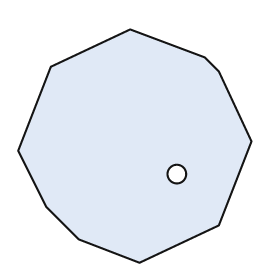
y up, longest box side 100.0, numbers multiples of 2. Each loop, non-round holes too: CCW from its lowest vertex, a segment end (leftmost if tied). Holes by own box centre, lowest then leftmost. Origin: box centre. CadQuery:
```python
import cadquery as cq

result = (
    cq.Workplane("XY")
    .moveTo(2.0, -50.0)
    .lineTo(36.0, -34.0)
    .lineTo(50.0, 2.0)
    .lineTo(36.0, 32.0)
    .lineTo(30.0, 38.0)
    .lineTo(-2.0, 50.0)
    .lineTo(-36.0, 34.0)
    .lineTo(-50.0, -2.0)
    .lineTo(-38.0, -26.0)
    .lineTo(-24.0, -40.0)
    .close()
    .moveTo(18.0, -12.0)
    .circle(4.0)
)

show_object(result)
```